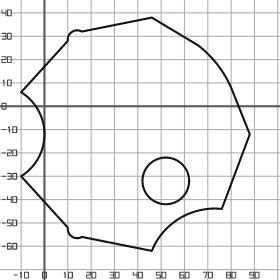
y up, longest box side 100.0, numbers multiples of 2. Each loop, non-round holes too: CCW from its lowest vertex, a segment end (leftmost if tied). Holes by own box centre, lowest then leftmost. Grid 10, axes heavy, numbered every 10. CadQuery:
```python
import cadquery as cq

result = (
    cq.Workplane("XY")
    .moveTo(46.0, -62.0)
    .threePointArc((58.0, -48.0), (76.0, -44.0))
    .lineTo(88.0, -12.0)
    .lineTo(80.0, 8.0)
    .threePointArc((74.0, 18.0), (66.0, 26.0))
    .lineTo(46.0, 38.0)
    .lineTo(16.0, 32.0)
    .threePointArc((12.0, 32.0), (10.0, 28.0))
    .lineTo(-10.0, 6.0)
    .threePointArc((0.0, -12.0), (-10.0, -30.0))
    .lineTo(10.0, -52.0)
    .threePointArc((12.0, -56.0), (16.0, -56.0))
    .close()
    .moveTo(52.0, -32.0)
    .circle(10.0)
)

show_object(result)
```